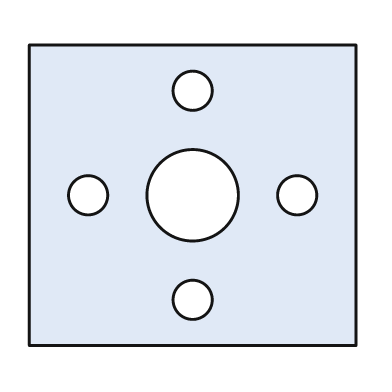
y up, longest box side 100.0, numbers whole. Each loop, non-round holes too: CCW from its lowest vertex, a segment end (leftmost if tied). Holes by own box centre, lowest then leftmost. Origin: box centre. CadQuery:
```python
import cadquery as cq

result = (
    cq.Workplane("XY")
    .moveTo(-50.0, -46.0)
    .lineTo(50.0, -46.0)
    .lineTo(50.0, 46.0)
    .lineTo(-50.0, 46.0)
    .close()
    .moveTo(0.0, -32.0)
    .circle(6.0)
    .moveTo(-32.0, 0.0)
    .circle(6.0)
    .moveTo(0.0, 0.0)
    .circle(14.0)
    .moveTo(32.0, 0.0)
    .circle(6.0)
    .moveTo(0.0, 32.0)
    .circle(6.0)
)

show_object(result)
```